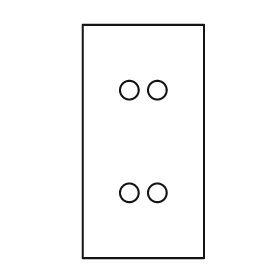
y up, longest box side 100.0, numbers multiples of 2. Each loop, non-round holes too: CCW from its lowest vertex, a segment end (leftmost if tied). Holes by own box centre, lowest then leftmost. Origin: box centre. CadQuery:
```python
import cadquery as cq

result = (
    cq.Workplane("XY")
    .moveTo(-26.0, -50.0)
    .lineTo(26.0, -50.0)
    .lineTo(26.0, 50.0)
    .lineTo(-26.0, 50.0)
    .close()
    .moveTo(-6.0, -22.0)
    .circle(4.0)
    .moveTo(6.0, -22.0)
    .circle(4.0)
    .moveTo(-6.0, 22.0)
    .circle(4.0)
    .moveTo(6.0, 22.0)
    .circle(4.0)
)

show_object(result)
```